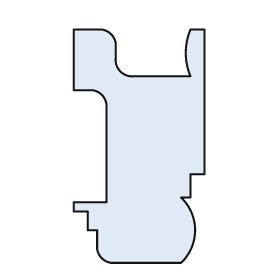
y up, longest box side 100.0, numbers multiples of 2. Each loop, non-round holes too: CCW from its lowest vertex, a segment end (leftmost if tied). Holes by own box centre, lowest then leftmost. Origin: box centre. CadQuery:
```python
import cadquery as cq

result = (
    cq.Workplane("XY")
    .moveTo(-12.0, -50.0)
    .lineTo(18.0, -50.0)
    .threePointArc((24.0, -36.0), (18.0, -22.0))
    .lineTo(22.0, -22.0)
    .lineTo(22.0, -12.0)
    .lineTo(28.0, -12.0)
    .lineTo(28.0, 50.0)
    .lineTo(22.0, 50.0)
    .threePointArc((20.0, 40.0), (22.0, 30.0))
    .lineTo(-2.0, 30.0)
    .threePointArc((-8.0, 32.0), (-10.0, 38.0))
    .lineTo(-10.0, 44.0)
    .threePointArc((-12.0, 48.0), (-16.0, 50.0))
    .lineTo(-28.0, 50.0)
    .lineTo(-28.0, 24.0)
    .lineTo(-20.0, 24.0)
    .threePointArc((-16.0, 22.0), (-14.0, 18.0))
    .lineTo(-14.0, -24.0)
    .lineTo(-28.0, -24.0)
    .lineTo(-28.0, -28.0)
    .lineTo(-22.0, -28.0)
    .lineTo(-22.0, -36.0)
    .lineTo(-18.0, -36.0)
    .lineTo(-18.0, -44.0)
    .threePointArc((-16.0, -48.0), (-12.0, -50.0))
    .close()
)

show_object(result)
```